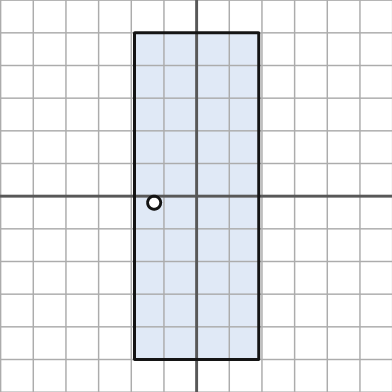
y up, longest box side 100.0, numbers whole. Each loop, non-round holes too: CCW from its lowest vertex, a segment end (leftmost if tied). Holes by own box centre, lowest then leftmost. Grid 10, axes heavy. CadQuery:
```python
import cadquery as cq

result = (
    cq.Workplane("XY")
    .moveTo(-19.0, -50.0)
    .lineTo(19.0, -50.0)
    .lineTo(19.0, 50.0)
    .lineTo(-19.0, 50.0)
    .close()
    .moveTo(-13.0, -2.0)
    .circle(2.0)
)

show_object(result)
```